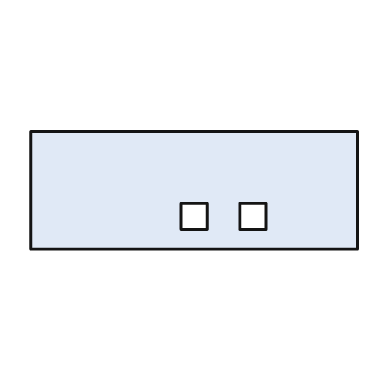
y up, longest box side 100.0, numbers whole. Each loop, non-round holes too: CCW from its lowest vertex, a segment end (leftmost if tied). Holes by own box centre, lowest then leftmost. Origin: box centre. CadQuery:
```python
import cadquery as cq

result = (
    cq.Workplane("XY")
    .moveTo(-50.0, -18.0)
    .lineTo(50.0, -18.0)
    .lineTo(50.0, 18.0)
    .lineTo(-50.0, 18.0)
    .close()
    .moveTo(-4.0, -12.0)
    .lineTo(4.0, -12.0)
    .lineTo(4.0, -4.0)
    .lineTo(-4.0, -4.0)
    .close()
    .moveTo(14.0, -12.0)
    .lineTo(22.0, -12.0)
    .lineTo(22.0, -4.0)
    .lineTo(14.0, -4.0)
    .close()
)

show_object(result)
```